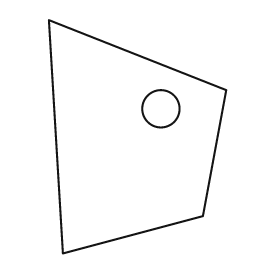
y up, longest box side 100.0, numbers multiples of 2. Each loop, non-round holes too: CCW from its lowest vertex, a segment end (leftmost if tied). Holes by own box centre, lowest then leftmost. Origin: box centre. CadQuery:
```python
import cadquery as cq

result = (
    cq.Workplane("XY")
    .moveTo(-32.0, -50.0)
    .lineTo(28.0, -34.0)
    .lineTo(38.0, 20.0)
    .lineTo(-38.0, 50.0)
    .close()
    .moveTo(10.0, 12.0)
    .circle(8.0)
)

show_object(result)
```